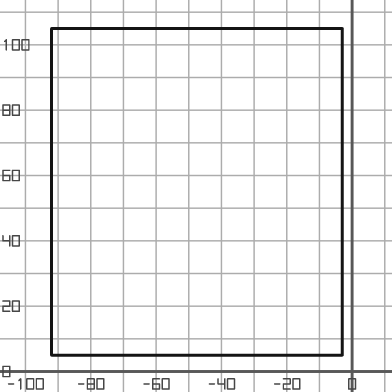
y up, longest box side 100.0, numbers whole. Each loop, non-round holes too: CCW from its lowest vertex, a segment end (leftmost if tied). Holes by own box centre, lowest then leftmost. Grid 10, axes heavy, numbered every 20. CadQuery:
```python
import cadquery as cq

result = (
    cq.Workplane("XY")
    .moveTo(-92.0, 5.0)
    .lineTo(-3.0, 5.0)
    .lineTo(-3.0, 105.0)
    .lineTo(-92.0, 105.0)
    .close()
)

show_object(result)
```